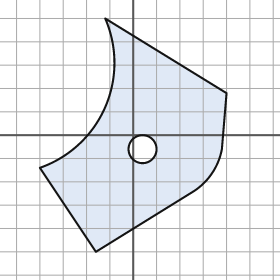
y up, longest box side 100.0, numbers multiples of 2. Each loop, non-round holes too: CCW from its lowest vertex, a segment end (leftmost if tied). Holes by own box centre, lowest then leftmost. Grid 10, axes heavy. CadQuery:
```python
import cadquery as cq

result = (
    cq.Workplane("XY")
    .moveTo(-16.0, -50.0)
    .lineTo(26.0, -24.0)
    .threePointArc((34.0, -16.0), (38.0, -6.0))
    .lineTo(40.0, 18.0)
    .lineTo(-12.0, 50.0)
    .threePointArc((-12.0, 12.0), (-40.0, -14.0))
    .close()
    .moveTo(4.0, -6.0)
    .circle(6.0)
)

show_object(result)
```